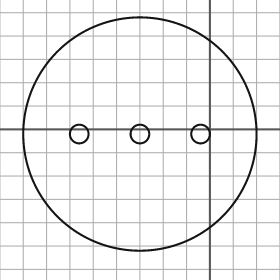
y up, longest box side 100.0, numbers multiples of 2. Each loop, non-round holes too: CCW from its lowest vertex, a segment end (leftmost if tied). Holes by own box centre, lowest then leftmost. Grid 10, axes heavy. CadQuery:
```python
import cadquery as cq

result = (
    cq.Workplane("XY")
    .moveTo(-30.0, -2.0)
    .circle(50.0)
    .moveTo(-56.0, -2.0)
    .circle(4.0)
    .moveTo(-30.0, -2.0)
    .circle(4.0)
    .moveTo(-4.0, -2.0)
    .circle(4.0)
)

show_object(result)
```